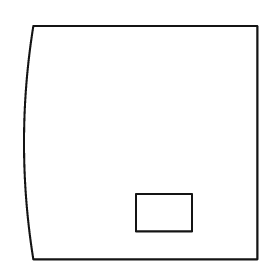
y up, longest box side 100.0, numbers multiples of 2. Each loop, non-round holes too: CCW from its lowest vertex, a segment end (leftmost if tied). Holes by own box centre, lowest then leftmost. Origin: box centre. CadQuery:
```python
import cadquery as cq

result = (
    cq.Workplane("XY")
    .moveTo(-46.0, -50.0)
    .lineTo(50.0, -50.0)
    .lineTo(50.0, 50.0)
    .lineTo(-46.0, 50.0)
    .threePointArc((-50.0, 0.0), (-46.0, -50.0))
    .close()
    .moveTo(-2.0, -38.0)
    .lineTo(22.0, -38.0)
    .lineTo(22.0, -22.0)
    .lineTo(-2.0, -22.0)
    .close()
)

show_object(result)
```